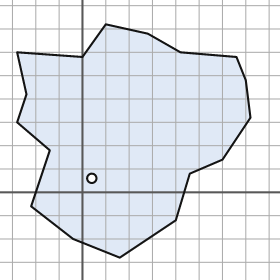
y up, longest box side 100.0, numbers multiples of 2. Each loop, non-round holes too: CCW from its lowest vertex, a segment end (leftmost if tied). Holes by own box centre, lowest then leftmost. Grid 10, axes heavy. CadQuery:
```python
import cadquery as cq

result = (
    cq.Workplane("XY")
    .moveTo(16.0, -28.0)
    .lineTo(40.0, -12.0)
    .lineTo(46.0, 8.0)
    .lineTo(60.0, 14.0)
    .lineTo(72.0, 32.0)
    .lineTo(70.0, 48.0)
    .lineTo(66.0, 58.0)
    .lineTo(42.0, 60.0)
    .lineTo(28.0, 68.0)
    .lineTo(10.0, 72.0)
    .lineTo(0.0, 58.0)
    .lineTo(-28.0, 60.0)
    .lineTo(-24.0, 42.0)
    .lineTo(-28.0, 30.0)
    .lineTo(-14.0, 18.0)
    .lineTo(-22.0, -6.0)
    .lineTo(-4.0, -20.0)
    .close()
    .moveTo(4.0, 6.0)
    .circle(2.0)
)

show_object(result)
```